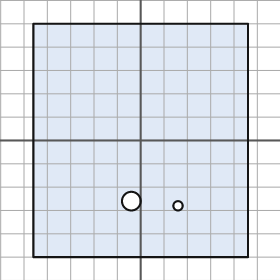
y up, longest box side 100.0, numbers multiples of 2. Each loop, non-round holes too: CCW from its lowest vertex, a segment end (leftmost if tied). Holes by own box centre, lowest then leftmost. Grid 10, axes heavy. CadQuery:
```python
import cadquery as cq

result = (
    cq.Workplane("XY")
    .moveTo(-46.0, -50.0)
    .lineTo(46.0, -50.0)
    .lineTo(46.0, 50.0)
    .lineTo(-46.0, 50.0)
    .close()
    .moveTo(16.0, -28.0)
    .circle(2.0)
    .moveTo(-4.0, -26.0)
    .circle(4.0)
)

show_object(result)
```